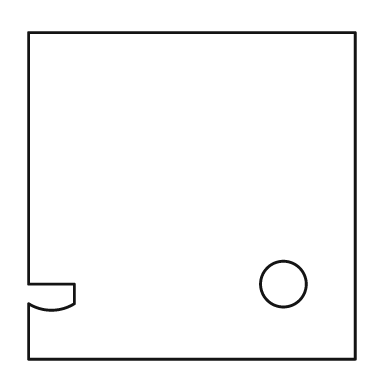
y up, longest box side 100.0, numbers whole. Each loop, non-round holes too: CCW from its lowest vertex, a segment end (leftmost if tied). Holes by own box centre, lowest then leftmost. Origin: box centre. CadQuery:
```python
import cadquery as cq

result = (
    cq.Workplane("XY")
    .moveTo(-50.0, -50.0)
    .lineTo(50.0, -50.0)
    .lineTo(50.0, 50.0)
    .lineTo(-50.0, 50.0)
    .lineTo(-50.0, -27.0)
    .lineTo(-36.0, -27.0)
    .lineTo(-36.0, -33.0)
    .threePointArc((-43.0, -35.0), (-50.0, -33.0))
    .close()
    .moveTo(28.0, -27.0)
    .circle(7.0)
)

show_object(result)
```